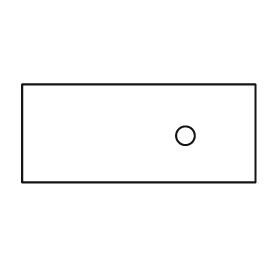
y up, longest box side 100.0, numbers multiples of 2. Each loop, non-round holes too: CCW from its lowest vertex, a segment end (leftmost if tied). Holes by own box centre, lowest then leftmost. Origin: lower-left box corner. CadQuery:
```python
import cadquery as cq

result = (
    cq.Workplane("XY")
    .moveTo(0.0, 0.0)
    .lineTo(100.0, 0.0)
    .lineTo(100.0, 42.0)
    .lineTo(0.0, 42.0)
    .close()
    .moveTo(70.0, 20.0)
    .circle(4.0)
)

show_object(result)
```